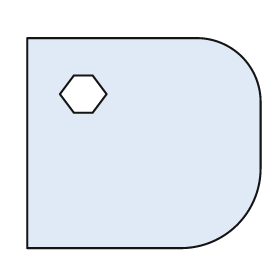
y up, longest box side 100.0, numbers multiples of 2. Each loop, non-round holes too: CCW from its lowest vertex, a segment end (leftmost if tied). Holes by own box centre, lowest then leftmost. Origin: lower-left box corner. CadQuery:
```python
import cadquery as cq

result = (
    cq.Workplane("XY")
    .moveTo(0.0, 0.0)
    .lineTo(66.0, 0.0)
    .threePointArc((90.0, 10.0), (100.0, 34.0))
    .lineTo(100.0, 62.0)
    .threePointArc((92.0, 82.0), (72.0, 90.0))
    .lineTo(0.0, 90.0)
    .close()
    .moveTo(20.0, 58.0)
    .lineTo(28.0, 58.0)
    .lineTo(34.0, 66.0)
    .lineTo(28.0, 74.0)
    .lineTo(20.0, 74.0)
    .lineTo(14.0, 66.0)
    .close()
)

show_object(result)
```